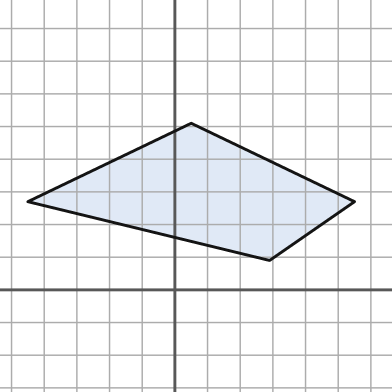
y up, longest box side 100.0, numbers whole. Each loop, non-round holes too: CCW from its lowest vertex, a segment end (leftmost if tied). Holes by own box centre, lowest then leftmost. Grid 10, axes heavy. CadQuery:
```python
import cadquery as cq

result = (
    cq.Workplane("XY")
    .moveTo(29.0, 9.0)
    .lineTo(55.0, 27.0)
    .lineTo(5.0, 51.0)
    .lineTo(-45.0, 27.0)
    .close()
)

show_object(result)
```